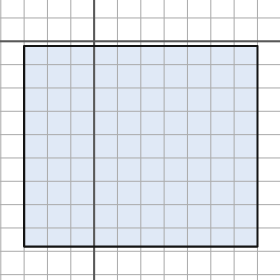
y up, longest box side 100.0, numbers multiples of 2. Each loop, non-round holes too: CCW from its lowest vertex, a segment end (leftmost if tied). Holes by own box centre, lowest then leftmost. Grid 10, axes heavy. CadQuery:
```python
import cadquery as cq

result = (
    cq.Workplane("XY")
    .moveTo(-30.0, -88.0)
    .lineTo(70.0, -88.0)
    .lineTo(70.0, -2.0)
    .lineTo(-30.0, -2.0)
    .close()
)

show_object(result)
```